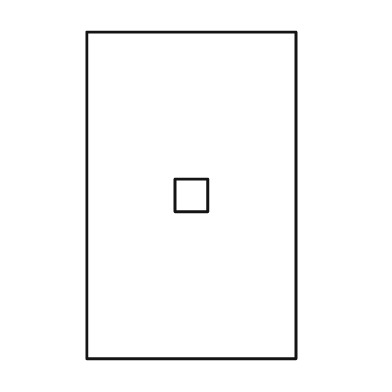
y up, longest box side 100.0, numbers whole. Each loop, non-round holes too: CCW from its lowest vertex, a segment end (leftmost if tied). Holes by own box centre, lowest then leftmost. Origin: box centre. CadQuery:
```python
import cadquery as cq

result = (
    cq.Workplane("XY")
    .moveTo(-32.0, -50.0)
    .lineTo(32.0, -50.0)
    .lineTo(32.0, 50.0)
    .lineTo(-32.0, 50.0)
    .close()
    .moveTo(-5.0, -5.0)
    .lineTo(5.0, -5.0)
    .lineTo(5.0, 5.0)
    .lineTo(-5.0, 5.0)
    .close()
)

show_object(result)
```